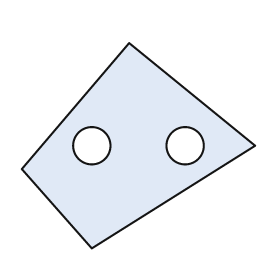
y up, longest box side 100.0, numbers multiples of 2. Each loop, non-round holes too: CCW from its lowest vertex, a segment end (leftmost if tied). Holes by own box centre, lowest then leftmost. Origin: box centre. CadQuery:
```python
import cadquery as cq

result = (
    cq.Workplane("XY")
    .moveTo(-20.0, -44.0)
    .lineTo(50.0, 0.0)
    .lineTo(-4.0, 44.0)
    .lineTo(-50.0, -10.0)
    .close()
    .moveTo(-20.0, 0.0)
    .circle(8.0)
    .moveTo(20.0, 0.0)
    .circle(8.0)
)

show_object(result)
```